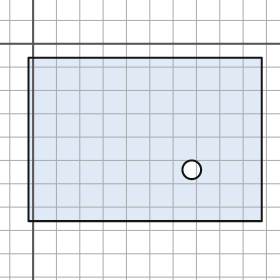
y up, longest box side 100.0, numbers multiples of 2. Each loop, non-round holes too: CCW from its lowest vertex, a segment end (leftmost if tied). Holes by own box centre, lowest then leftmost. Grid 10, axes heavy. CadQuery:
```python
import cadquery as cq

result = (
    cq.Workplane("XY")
    .moveTo(-2.0, -76.0)
    .lineTo(98.0, -76.0)
    .lineTo(98.0, -6.0)
    .lineTo(-2.0, -6.0)
    .close()
    .moveTo(68.0, -54.0)
    .circle(4.0)
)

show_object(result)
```